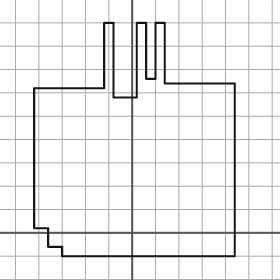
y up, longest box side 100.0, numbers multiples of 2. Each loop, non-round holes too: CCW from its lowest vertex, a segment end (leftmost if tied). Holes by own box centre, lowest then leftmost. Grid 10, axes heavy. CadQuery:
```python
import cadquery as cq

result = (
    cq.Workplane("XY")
    .moveTo(-30.0, -10.0)
    .lineTo(44.0, -10.0)
    .lineTo(44.0, 64.0)
    .lineTo(14.0, 64.0)
    .lineTo(14.0, 90.0)
    .lineTo(10.0, 90.0)
    .lineTo(10.0, 66.0)
    .lineTo(6.0, 66.0)
    .lineTo(6.0, 90.0)
    .lineTo(2.0, 90.0)
    .lineTo(2.0, 58.0)
    .lineTo(-8.0, 58.0)
    .lineTo(-8.0, 90.0)
    .lineTo(-12.0, 90.0)
    .lineTo(-12.0, 62.0)
    .lineTo(-42.0, 62.0)
    .lineTo(-42.0, 2.0)
    .lineTo(-36.0, 2.0)
    .lineTo(-36.0, -6.0)
    .lineTo(-30.0, -6.0)
    .close()
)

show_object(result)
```